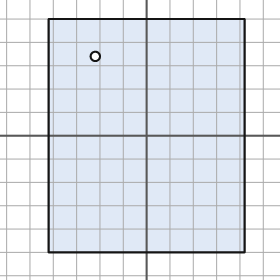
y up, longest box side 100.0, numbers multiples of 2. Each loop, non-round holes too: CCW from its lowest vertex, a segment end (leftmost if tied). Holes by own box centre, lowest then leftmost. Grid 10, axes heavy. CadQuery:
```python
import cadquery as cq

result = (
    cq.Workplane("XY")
    .moveTo(-42.0, -50.0)
    .lineTo(42.0, -50.0)
    .lineTo(42.0, 50.0)
    .lineTo(-42.0, 50.0)
    .close()
    .moveTo(-22.0, 34.0)
    .circle(2.0)
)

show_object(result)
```